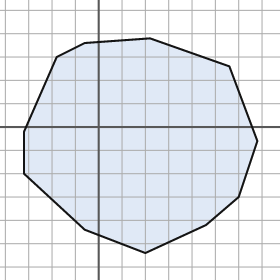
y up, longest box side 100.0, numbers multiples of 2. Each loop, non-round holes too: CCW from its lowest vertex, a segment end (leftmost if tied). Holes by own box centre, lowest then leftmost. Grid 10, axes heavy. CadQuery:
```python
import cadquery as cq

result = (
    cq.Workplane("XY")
    .moveTo(20.0, -54.0)
    .lineTo(46.0, -42.0)
    .lineTo(60.0, -30.0)
    .lineTo(68.0, -6.0)
    .lineTo(56.0, 26.0)
    .lineTo(22.0, 38.0)
    .lineTo(-6.0, 36.0)
    .lineTo(-18.0, 30.0)
    .lineTo(-32.0, -2.0)
    .lineTo(-32.0, -20.0)
    .lineTo(-6.0, -44.0)
    .close()
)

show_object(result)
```